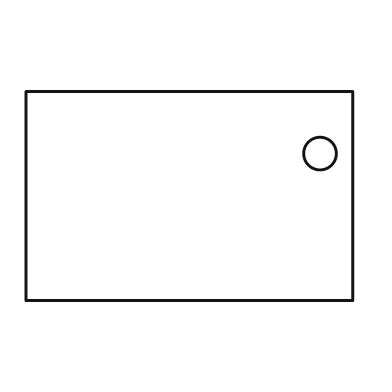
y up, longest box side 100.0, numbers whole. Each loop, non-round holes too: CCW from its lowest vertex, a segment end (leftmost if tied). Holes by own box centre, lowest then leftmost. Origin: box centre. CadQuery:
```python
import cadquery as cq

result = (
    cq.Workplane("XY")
    .moveTo(-50.0, -32.0)
    .lineTo(50.0, -32.0)
    .lineTo(50.0, 32.0)
    .lineTo(-50.0, 32.0)
    .close()
    .moveTo(40.0, 13.0)
    .circle(5.0)
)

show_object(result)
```